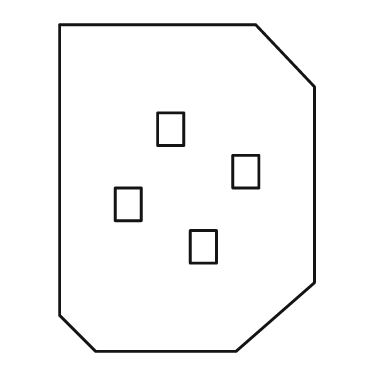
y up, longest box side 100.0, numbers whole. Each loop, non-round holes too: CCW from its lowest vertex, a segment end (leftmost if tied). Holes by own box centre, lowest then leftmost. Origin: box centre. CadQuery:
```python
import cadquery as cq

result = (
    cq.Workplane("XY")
    .moveTo(-28.0, -50.0)
    .lineTo(15.0, -50.0)
    .lineTo(39.0, -29.0)
    .lineTo(39.0, 31.0)
    .lineTo(21.0, 50.0)
    .lineTo(-39.0, 50.0)
    .lineTo(-39.0, -39.0)
    .close()
    .moveTo(1.0, -23.0)
    .lineTo(9.0, -23.0)
    .lineTo(9.0, -13.0)
    .lineTo(1.0, -13.0)
    .close()
    .moveTo(-22.0, -10.0)
    .lineTo(-14.0, -10.0)
    .lineTo(-14.0, 0.0)
    .lineTo(-22.0, 0.0)
    .close()
    .moveTo(14.0, 0.0)
    .lineTo(22.0, 0.0)
    .lineTo(22.0, 10.0)
    .lineTo(14.0, 10.0)
    .close()
    .moveTo(-9.0, 13.0)
    .lineTo(-1.0, 13.0)
    .lineTo(-1.0, 23.0)
    .lineTo(-9.0, 23.0)
    .close()
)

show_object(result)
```